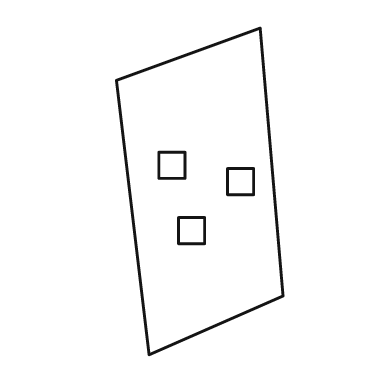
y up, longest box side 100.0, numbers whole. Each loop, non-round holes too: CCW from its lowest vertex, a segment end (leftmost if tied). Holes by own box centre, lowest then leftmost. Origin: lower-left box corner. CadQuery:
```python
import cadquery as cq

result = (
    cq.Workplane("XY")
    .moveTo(10.0, 0.0)
    .lineTo(51.0, 18.0)
    .lineTo(44.0, 100.0)
    .lineTo(0.0, 84.0)
    .close()
    .moveTo(19.0, 34.0)
    .lineTo(27.0, 34.0)
    .lineTo(27.0, 42.0)
    .lineTo(19.0, 42.0)
    .close()
    .moveTo(34.0, 49.0)
    .lineTo(42.0, 49.0)
    .lineTo(42.0, 57.0)
    .lineTo(34.0, 57.0)
    .close()
    .moveTo(13.0, 54.0)
    .lineTo(21.0, 54.0)
    .lineTo(21.0, 62.0)
    .lineTo(13.0, 62.0)
    .close()
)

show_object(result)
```